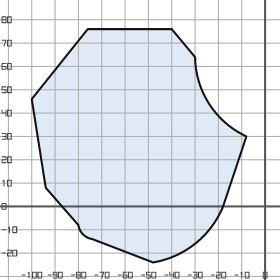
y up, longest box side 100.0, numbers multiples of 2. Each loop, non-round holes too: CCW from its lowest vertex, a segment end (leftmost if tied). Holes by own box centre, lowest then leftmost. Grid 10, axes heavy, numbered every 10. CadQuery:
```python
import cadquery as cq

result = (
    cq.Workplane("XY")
    .moveTo(-48.0, -24.0)
    .threePointArc((-30.0, -16.0), (-18.0, 0.0))
    .lineTo(-8.0, 30.0)
    .threePointArc((-24.0, 44.0), (-30.0, 64.0))
    .lineTo(-40.0, 76.0)
    .lineTo(-76.0, 76.0)
    .lineTo(-100.0, 46.0)
    .lineTo(-94.0, 8.0)
    .lineTo(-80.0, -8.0)
    .threePointArc((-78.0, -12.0), (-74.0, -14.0))
    .close()
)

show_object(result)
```